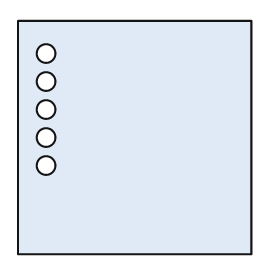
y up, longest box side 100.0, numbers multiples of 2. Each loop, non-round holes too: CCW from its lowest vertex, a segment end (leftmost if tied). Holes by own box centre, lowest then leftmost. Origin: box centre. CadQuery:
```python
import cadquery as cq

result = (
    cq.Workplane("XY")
    .moveTo(-50.0, -50.0)
    .lineTo(50.0, -50.0)
    .lineTo(50.0, 50.0)
    .lineTo(-50.0, 50.0)
    .close()
    .moveTo(-38.0, -12.0)
    .circle(4.0)
    .moveTo(-38.0, 0.0)
    .circle(4.0)
    .moveTo(-38.0, 12.0)
    .circle(4.0)
    .moveTo(-38.0, 24.0)
    .circle(4.0)
    .moveTo(-38.0, 36.0)
    .circle(4.0)
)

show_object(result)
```